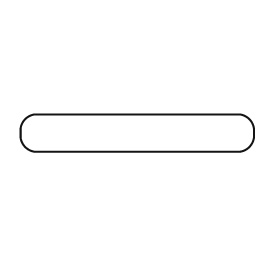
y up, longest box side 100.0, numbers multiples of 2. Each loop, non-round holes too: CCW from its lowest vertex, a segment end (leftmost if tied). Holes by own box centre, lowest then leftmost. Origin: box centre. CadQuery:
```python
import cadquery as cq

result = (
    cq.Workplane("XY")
    .moveTo(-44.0, -8.0)
    .lineTo(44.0, -8.0)
    .threePointArc((48.0, -6.0), (50.0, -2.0))
    .lineTo(50.0, 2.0)
    .threePointArc((48.0, 6.0), (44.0, 8.0))
    .lineTo(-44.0, 8.0)
    .threePointArc((-48.0, 6.0), (-50.0, 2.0))
    .lineTo(-50.0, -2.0)
    .threePointArc((-48.0, -6.0), (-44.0, -8.0))
    .close()
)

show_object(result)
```